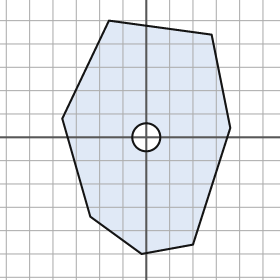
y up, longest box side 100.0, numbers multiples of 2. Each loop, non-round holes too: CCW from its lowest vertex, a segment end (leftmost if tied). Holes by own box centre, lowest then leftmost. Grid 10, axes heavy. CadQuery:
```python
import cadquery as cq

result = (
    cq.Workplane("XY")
    .moveTo(-2.0, -50.0)
    .lineTo(20.0, -46.0)
    .lineTo(36.0, 4.0)
    .lineTo(28.0, 44.0)
    .lineTo(-16.0, 50.0)
    .lineTo(-36.0, 8.0)
    .lineTo(-24.0, -34.0)
    .close()
    .moveTo(0.0, 0.0)
    .circle(6.0)
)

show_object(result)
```